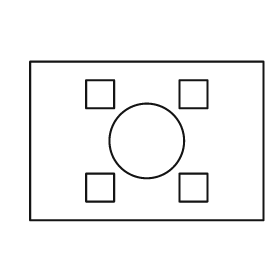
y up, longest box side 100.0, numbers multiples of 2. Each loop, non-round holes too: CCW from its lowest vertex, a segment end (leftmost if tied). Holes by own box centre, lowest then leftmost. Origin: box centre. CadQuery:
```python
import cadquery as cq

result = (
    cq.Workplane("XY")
    .moveTo(-50.0, -34.0)
    .lineTo(50.0, -34.0)
    .lineTo(50.0, 34.0)
    .lineTo(-50.0, 34.0)
    .close()
    .moveTo(-26.0, -26.0)
    .lineTo(-14.0, -26.0)
    .lineTo(-14.0, -14.0)
    .lineTo(-26.0, -14.0)
    .close()
    .moveTo(14.0, -26.0)
    .lineTo(26.0, -26.0)
    .lineTo(26.0, -14.0)
    .lineTo(14.0, -14.0)
    .close()
    .moveTo(0.0, 0.0)
    .circle(16.0)
    .moveTo(-26.0, 14.0)
    .lineTo(-14.0, 14.0)
    .lineTo(-14.0, 26.0)
    .lineTo(-26.0, 26.0)
    .close()
    .moveTo(14.0, 14.0)
    .lineTo(26.0, 14.0)
    .lineTo(26.0, 26.0)
    .lineTo(14.0, 26.0)
    .close()
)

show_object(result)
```